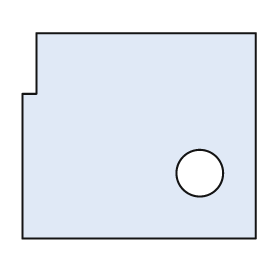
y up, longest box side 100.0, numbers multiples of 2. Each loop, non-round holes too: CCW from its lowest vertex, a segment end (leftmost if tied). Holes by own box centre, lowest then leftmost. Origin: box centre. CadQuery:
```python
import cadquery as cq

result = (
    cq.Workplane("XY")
    .moveTo(-50.0, -44.0)
    .lineTo(50.0, -44.0)
    .lineTo(50.0, 44.0)
    .lineTo(-44.0, 44.0)
    .lineTo(-44.0, 18.0)
    .lineTo(-50.0, 18.0)
    .close()
    .moveTo(26.0, -16.0)
    .circle(10.0)
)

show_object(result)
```